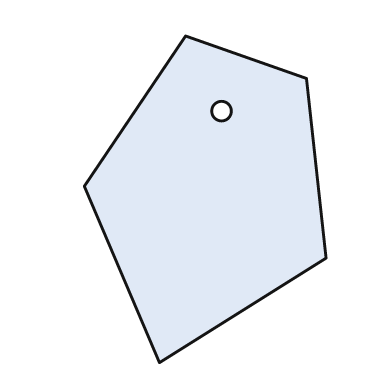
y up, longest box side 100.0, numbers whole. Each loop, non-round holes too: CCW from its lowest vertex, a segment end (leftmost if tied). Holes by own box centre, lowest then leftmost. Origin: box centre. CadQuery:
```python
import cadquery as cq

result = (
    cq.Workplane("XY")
    .moveTo(-14.0, -50.0)
    .lineTo(37.0, -18.0)
    .lineTo(31.0, 37.0)
    .lineTo(-6.0, 50.0)
    .lineTo(-37.0, 4.0)
    .close()
    .moveTo(5.0, 27.0)
    .circle(3.0)
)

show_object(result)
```